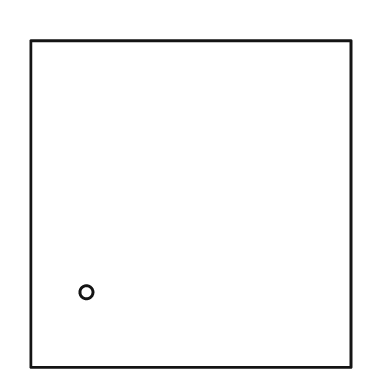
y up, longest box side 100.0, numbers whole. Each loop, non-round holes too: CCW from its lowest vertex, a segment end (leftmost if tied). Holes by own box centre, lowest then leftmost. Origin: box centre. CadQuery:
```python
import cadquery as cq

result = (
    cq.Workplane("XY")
    .moveTo(-49.0, -50.0)
    .lineTo(49.0, -50.0)
    .lineTo(49.0, 50.0)
    .lineTo(-49.0, 50.0)
    .close()
    .moveTo(-32.0, -27.0)
    .circle(2.0)
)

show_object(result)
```